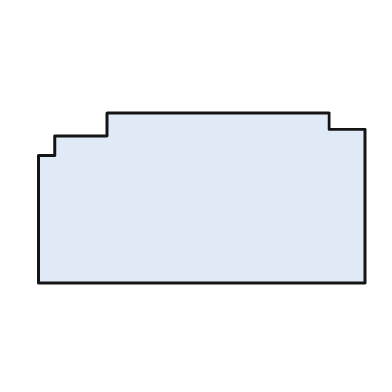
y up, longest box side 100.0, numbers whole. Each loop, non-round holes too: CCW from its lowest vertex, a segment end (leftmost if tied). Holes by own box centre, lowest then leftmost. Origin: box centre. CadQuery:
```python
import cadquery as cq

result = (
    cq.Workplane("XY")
    .moveTo(-50.0, -26.0)
    .lineTo(50.0, -26.0)
    .lineTo(50.0, 21.0)
    .lineTo(39.0, 21.0)
    .lineTo(39.0, 26.0)
    .lineTo(-29.0, 26.0)
    .lineTo(-29.0, 19.0)
    .lineTo(-45.0, 19.0)
    .lineTo(-45.0, 13.0)
    .lineTo(-50.0, 13.0)
    .close()
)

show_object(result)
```